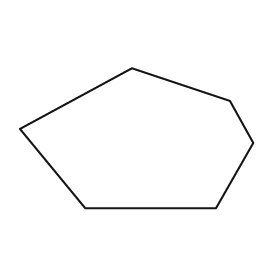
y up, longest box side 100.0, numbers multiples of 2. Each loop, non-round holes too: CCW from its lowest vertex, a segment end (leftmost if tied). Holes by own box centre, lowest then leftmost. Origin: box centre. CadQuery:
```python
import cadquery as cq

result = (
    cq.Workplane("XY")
    .moveTo(-22.0, -30.0)
    .lineTo(34.0, -30.0)
    .lineTo(50.0, -2.0)
    .lineTo(40.0, 16.0)
    .lineTo(-2.0, 30.0)
    .lineTo(-50.0, 4.0)
    .close()
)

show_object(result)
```